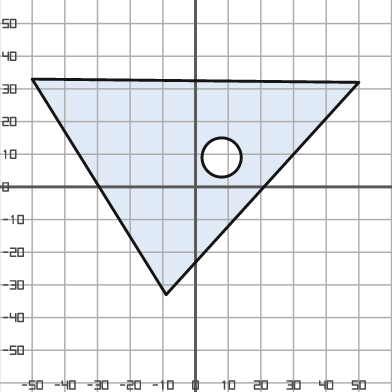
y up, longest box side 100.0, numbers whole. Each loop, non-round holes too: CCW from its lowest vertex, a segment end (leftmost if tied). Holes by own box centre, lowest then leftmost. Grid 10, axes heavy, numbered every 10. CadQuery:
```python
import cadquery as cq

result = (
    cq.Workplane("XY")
    .moveTo(-9.0, -33.0)
    .lineTo(50.0, 32.0)
    .lineTo(-50.0, 33.0)
    .close()
    .moveTo(8.0, 9.0)
    .circle(6.0)
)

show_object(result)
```